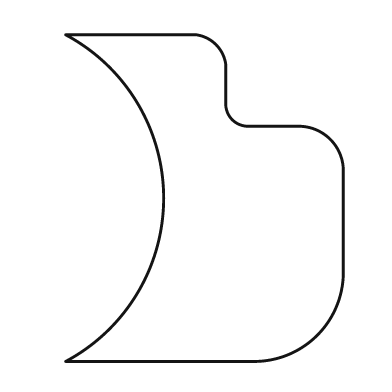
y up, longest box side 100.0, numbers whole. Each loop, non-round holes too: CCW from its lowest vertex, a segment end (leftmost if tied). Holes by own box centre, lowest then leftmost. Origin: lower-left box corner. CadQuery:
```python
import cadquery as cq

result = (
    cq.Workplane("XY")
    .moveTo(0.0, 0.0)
    .lineTo(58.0, 0.0)
    .threePointArc((77.0, 8.0), (85.0, 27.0))
    .lineTo(85.0, 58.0)
    .threePointArc((81.0, 68.0), (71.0, 72.0))
    .lineTo(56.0, 72.0)
    .threePointArc((51.0, 74.0), (49.0, 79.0))
    .lineTo(49.0, 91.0)
    .threePointArc((46.0, 97.0), (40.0, 100.0))
    .lineTo(0.0, 100.0)
    .threePointArc((30.0, 50.0), (0.0, 0.0))
    .close()
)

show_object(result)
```